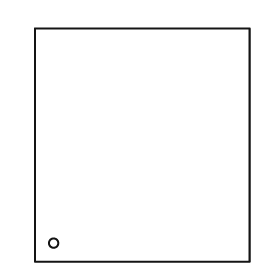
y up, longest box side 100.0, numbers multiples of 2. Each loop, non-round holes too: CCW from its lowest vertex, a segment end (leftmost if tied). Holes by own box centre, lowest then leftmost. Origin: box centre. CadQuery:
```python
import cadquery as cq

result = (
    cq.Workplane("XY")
    .moveTo(-46.0, -50.0)
    .lineTo(46.0, -50.0)
    .lineTo(46.0, 50.0)
    .lineTo(-46.0, 50.0)
    .close()
    .moveTo(-38.0, -42.0)
    .circle(2.0)
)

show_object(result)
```